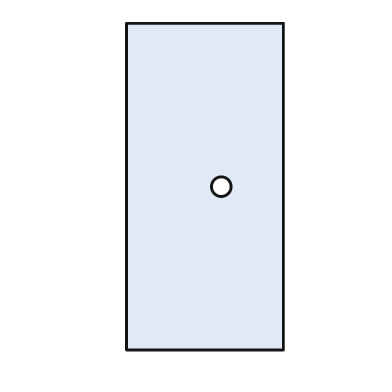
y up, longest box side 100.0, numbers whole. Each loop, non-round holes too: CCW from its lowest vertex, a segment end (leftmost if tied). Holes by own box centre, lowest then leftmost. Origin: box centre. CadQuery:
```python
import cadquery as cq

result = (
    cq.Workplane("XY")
    .moveTo(-24.0, -50.0)
    .lineTo(24.0, -50.0)
    .lineTo(24.0, 50.0)
    .lineTo(-24.0, 50.0)
    .close()
    .moveTo(5.0, 0.0)
    .circle(3.0)
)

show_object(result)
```